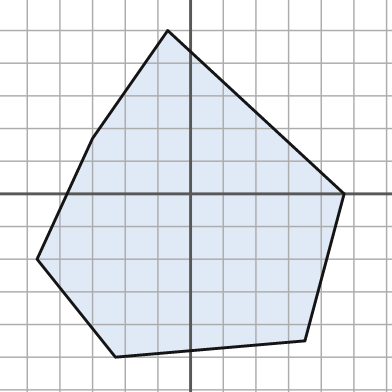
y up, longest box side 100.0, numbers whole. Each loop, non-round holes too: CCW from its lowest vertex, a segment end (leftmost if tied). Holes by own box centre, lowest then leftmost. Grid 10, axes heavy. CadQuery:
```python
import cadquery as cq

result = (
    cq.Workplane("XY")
    .moveTo(-23.0, -50.0)
    .lineTo(35.0, -45.0)
    .lineTo(47.0, 0.0)
    .lineTo(-7.0, 50.0)
    .lineTo(-30.0, 17.0)
    .lineTo(-47.0, -20.0)
    .close()
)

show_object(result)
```